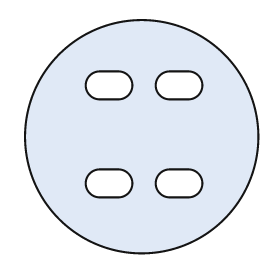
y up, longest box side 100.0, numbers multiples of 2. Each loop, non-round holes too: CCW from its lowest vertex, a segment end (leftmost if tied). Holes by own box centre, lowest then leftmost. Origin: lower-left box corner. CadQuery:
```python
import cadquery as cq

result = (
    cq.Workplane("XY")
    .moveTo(50.0, 50.0)
    .circle(50.0)
    .moveTo(32.0, 24.0)
    .lineTo(40.0, 24.0)
    .threePointArc((46.0, 30.0), (40.0, 36.0))
    .lineTo(32.0, 36.0)
    .threePointArc((26.0, 30.0), (32.0, 24.0))
    .close()
    .moveTo(62.0, 24.0)
    .lineTo(70.0, 24.0)
    .threePointArc((76.0, 30.0), (70.0, 36.0))
    .lineTo(62.0, 36.0)
    .threePointArc((56.0, 30.0), (62.0, 24.0))
    .close()
    .moveTo(32.0, 66.0)
    .lineTo(40.0, 66.0)
    .threePointArc((46.0, 72.0), (40.0, 78.0))
    .lineTo(32.0, 78.0)
    .threePointArc((26.0, 72.0), (32.0, 66.0))
    .close()
    .moveTo(62.0, 66.0)
    .lineTo(70.0, 66.0)
    .threePointArc((76.0, 72.0), (70.0, 78.0))
    .lineTo(62.0, 78.0)
    .threePointArc((56.0, 72.0), (62.0, 66.0))
    .close()
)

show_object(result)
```